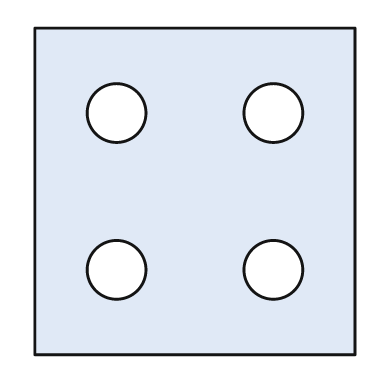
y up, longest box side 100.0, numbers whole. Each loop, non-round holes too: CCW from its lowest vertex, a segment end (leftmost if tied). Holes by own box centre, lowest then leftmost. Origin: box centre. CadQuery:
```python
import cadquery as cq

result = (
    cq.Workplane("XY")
    .moveTo(-49.0, -50.0)
    .lineTo(49.0, -50.0)
    .lineTo(49.0, 50.0)
    .lineTo(-49.0, 50.0)
    .close()
    .moveTo(-24.0, -24.0)
    .circle(9.0)
    .moveTo(24.0, -24.0)
    .circle(9.0)
    .moveTo(-24.0, 24.0)
    .circle(9.0)
    .moveTo(24.0, 24.0)
    .circle(9.0)
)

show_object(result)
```